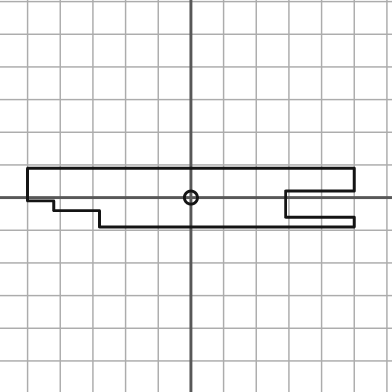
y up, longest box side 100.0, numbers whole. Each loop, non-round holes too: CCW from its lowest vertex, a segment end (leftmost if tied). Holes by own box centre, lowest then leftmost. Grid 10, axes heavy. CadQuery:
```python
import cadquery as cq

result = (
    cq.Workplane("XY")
    .moveTo(-28.0, -9.0)
    .lineTo(50.0, -9.0)
    .lineTo(50.0, -6.0)
    .lineTo(29.0, -6.0)
    .lineTo(29.0, 2.0)
    .lineTo(50.0, 2.0)
    .lineTo(50.0, 9.0)
    .lineTo(-50.0, 9.0)
    .lineTo(-50.0, -1.0)
    .lineTo(-42.0, -1.0)
    .lineTo(-42.0, -4.0)
    .lineTo(-28.0, -4.0)
    .close()
    .moveTo(0.0, 0.0)
    .circle(2.0)
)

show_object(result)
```